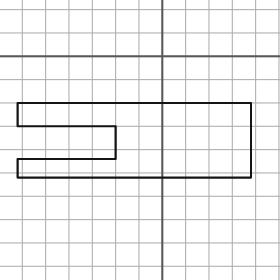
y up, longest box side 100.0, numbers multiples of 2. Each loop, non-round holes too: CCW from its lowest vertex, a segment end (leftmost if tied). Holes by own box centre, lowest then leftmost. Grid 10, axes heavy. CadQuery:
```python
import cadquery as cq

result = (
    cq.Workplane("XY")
    .moveTo(-62.0, -52.0)
    .lineTo(38.0, -52.0)
    .lineTo(38.0, -20.0)
    .lineTo(-62.0, -20.0)
    .lineTo(-62.0, -30.0)
    .lineTo(-20.0, -30.0)
    .lineTo(-20.0, -44.0)
    .lineTo(-62.0, -44.0)
    .close()
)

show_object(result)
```